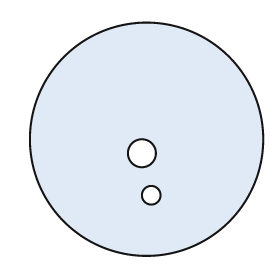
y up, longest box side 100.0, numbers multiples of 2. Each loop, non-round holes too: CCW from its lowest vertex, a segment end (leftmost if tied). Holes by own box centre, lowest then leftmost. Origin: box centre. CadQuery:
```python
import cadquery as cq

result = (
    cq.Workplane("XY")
    .moveTo(0.0, 0.0)
    .circle(50.0)
    .moveTo(2.0, -24.0)
    .circle(4.0)
    .moveTo(-2.0, -6.0)
    .circle(6.0)
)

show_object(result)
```